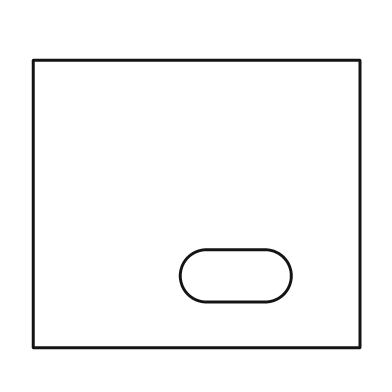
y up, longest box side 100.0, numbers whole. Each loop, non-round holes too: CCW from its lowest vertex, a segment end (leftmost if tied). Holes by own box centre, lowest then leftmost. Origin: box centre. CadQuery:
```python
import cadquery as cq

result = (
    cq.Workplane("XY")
    .moveTo(-50.0, -44.0)
    .lineTo(50.0, -44.0)
    .lineTo(50.0, 44.0)
    .lineTo(-50.0, 44.0)
    .close()
    .moveTo(3.0, -30.0)
    .lineTo(21.0, -30.0)
    .threePointArc((29.0, -22.0), (21.0, -14.0))
    .lineTo(3.0, -14.0)
    .threePointArc((-5.0, -22.0), (3.0, -30.0))
    .close()
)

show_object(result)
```